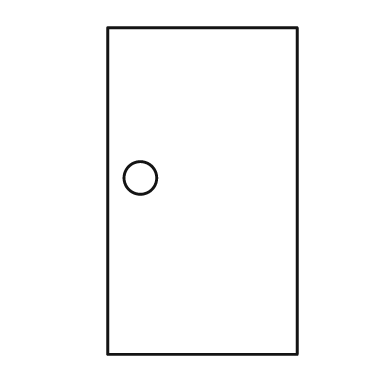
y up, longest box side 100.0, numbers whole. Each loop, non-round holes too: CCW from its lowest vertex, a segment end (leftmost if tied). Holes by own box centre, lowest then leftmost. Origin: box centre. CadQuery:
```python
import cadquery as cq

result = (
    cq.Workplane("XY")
    .moveTo(-29.0, -50.0)
    .lineTo(29.0, -50.0)
    .lineTo(29.0, 50.0)
    .lineTo(-29.0, 50.0)
    .close()
    .moveTo(-19.0, 4.0)
    .circle(5.0)
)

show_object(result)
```